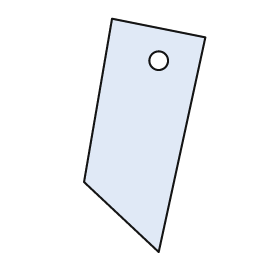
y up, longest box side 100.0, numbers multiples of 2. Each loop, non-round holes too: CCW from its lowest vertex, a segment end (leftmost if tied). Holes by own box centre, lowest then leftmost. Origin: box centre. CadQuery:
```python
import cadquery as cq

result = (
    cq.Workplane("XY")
    .moveTo(6.0, -50.0)
    .lineTo(26.0, 42.0)
    .lineTo(-14.0, 50.0)
    .lineTo(-26.0, -20.0)
    .close()
    .moveTo(6.0, 32.0)
    .circle(4.0)
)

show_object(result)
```